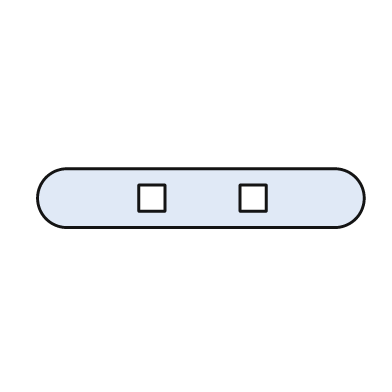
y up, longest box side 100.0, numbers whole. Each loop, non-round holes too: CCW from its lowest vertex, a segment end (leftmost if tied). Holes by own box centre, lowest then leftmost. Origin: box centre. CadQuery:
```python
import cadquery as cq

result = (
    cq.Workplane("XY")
    .moveTo(-41.0, -9.0)
    .lineTo(41.0, -9.0)
    .threePointArc((50.0, 0.0), (41.0, 9.0))
    .lineTo(-41.0, 9.0)
    .threePointArc((-50.0, 0.0), (-41.0, -9.0))
    .close()
    .moveTo(-19.0, -4.0)
    .lineTo(-11.0, -4.0)
    .lineTo(-11.0, 4.0)
    .lineTo(-19.0, 4.0)
    .close()
    .moveTo(12.0, -4.0)
    .lineTo(20.0, -4.0)
    .lineTo(20.0, 4.0)
    .lineTo(12.0, 4.0)
    .close()
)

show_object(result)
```